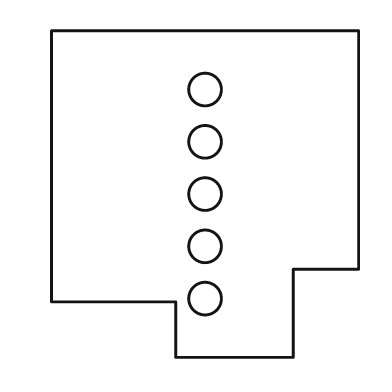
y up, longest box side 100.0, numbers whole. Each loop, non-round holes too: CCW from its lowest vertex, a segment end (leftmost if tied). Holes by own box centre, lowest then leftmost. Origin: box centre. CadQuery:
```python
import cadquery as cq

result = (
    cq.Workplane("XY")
    .moveTo(-9.0, -50.0)
    .lineTo(27.0, -50.0)
    .lineTo(27.0, -23.0)
    .lineTo(47.0, -23.0)
    .lineTo(47.0, 50.0)
    .lineTo(-47.0, 50.0)
    .lineTo(-47.0, -33.0)
    .lineTo(-9.0, -33.0)
    .close()
    .moveTo(0.0, -32.0)
    .circle(5.0)
    .moveTo(0.0, -16.0)
    .circle(5.0)
    .moveTo(0.0, 0.0)
    .circle(5.0)
    .moveTo(0.0, 16.0)
    .circle(5.0)
    .moveTo(0.0, 32.0)
    .circle(5.0)
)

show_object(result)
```